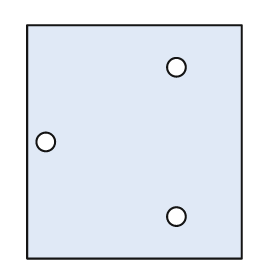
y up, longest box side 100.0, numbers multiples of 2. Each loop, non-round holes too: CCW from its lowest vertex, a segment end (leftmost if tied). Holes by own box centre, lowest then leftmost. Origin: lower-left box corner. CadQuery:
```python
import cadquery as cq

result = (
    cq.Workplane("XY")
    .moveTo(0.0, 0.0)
    .lineTo(92.0, 0.0)
    .lineTo(92.0, 100.0)
    .lineTo(0.0, 100.0)
    .close()
    .moveTo(64.0, 18.0)
    .circle(4.0)
    .moveTo(8.0, 50.0)
    .circle(4.0)
    .moveTo(64.0, 82.0)
    .circle(4.0)
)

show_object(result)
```